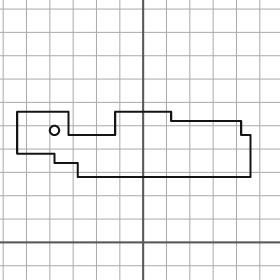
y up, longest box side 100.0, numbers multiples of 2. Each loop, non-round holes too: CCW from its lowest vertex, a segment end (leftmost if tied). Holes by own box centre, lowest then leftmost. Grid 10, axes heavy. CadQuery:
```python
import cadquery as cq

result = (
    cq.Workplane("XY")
    .moveTo(-28.0, 28.0)
    .lineTo(46.0, 28.0)
    .lineTo(46.0, 46.0)
    .lineTo(42.0, 46.0)
    .lineTo(42.0, 52.0)
    .lineTo(12.0, 52.0)
    .lineTo(12.0, 56.0)
    .lineTo(-12.0, 56.0)
    .lineTo(-12.0, 46.0)
    .lineTo(-32.0, 46.0)
    .lineTo(-32.0, 56.0)
    .lineTo(-54.0, 56.0)
    .lineTo(-54.0, 38.0)
    .lineTo(-38.0, 38.0)
    .lineTo(-38.0, 34.0)
    .lineTo(-28.0, 34.0)
    .close()
    .moveTo(-38.0, 48.0)
    .circle(2.0)
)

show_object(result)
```